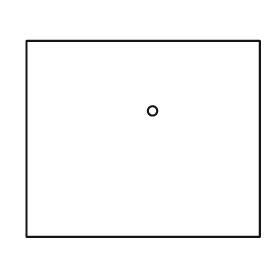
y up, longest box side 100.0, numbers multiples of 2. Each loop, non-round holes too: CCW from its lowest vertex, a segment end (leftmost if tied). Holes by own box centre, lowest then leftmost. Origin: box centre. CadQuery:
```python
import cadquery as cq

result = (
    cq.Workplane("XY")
    .moveTo(-50.0, -42.0)
    .lineTo(50.0, -42.0)
    .lineTo(50.0, 42.0)
    .lineTo(-50.0, 42.0)
    .close()
    .moveTo(4.0, 12.0)
    .circle(2.0)
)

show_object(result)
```